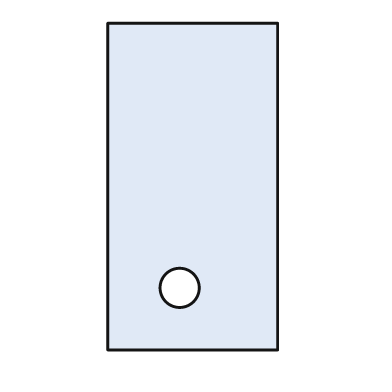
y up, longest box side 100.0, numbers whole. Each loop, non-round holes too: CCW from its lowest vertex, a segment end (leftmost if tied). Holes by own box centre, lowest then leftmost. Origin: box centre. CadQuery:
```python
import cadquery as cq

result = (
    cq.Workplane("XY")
    .moveTo(-26.0, -50.0)
    .lineTo(26.0, -50.0)
    .lineTo(26.0, 50.0)
    .lineTo(-26.0, 50.0)
    .close()
    .moveTo(-4.0, -31.0)
    .circle(6.0)
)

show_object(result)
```